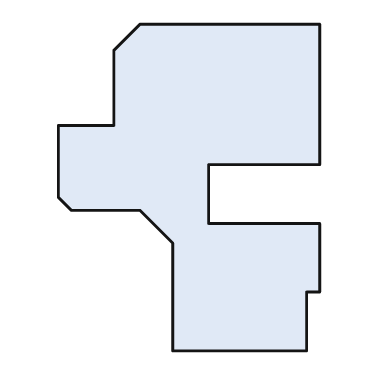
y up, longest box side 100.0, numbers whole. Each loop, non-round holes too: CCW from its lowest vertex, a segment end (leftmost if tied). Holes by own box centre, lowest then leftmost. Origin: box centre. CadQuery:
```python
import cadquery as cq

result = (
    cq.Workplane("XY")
    .moveTo(-5.0, -50.0)
    .lineTo(36.0, -50.0)
    .lineTo(36.0, -32.0)
    .lineTo(40.0, -32.0)
    .lineTo(40.0, -11.0)
    .lineTo(6.0, -11.0)
    .lineTo(6.0, 7.0)
    .lineTo(40.0, 7.0)
    .lineTo(40.0, 50.0)
    .lineTo(-15.0, 50.0)
    .lineTo(-23.0, 42.0)
    .lineTo(-23.0, 19.0)
    .lineTo(-40.0, 19.0)
    .lineTo(-40.0, -3.0)
    .lineTo(-36.0, -7.0)
    .lineTo(-15.0, -7.0)
    .lineTo(-5.0, -17.0)
    .close()
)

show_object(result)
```